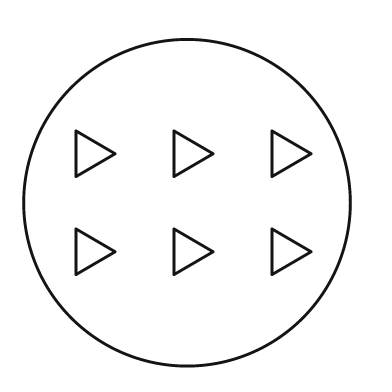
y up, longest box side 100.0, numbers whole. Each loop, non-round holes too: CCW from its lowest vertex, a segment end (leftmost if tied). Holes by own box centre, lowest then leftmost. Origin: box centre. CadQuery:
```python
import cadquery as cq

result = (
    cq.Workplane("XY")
    .moveTo(0.0, 0.0)
    .circle(50.0)
    .moveTo(-34.0, -22.0)
    .lineTo(-22.0, -15.0)
    .lineTo(-34.0, -8.0)
    .close()
    .moveTo(-4.0, -22.0)
    .lineTo(8.0, -15.0)
    .lineTo(-4.0, -8.0)
    .close()
    .moveTo(26.0, -22.0)
    .lineTo(38.0, -15.0)
    .lineTo(26.0, -8.0)
    .close()
    .moveTo(-34.0, 8.0)
    .lineTo(-22.0, 15.0)
    .lineTo(-34.0, 22.0)
    .close()
    .moveTo(-4.0, 8.0)
    .lineTo(8.0, 15.0)
    .lineTo(-4.0, 22.0)
    .close()
    .moveTo(26.0, 8.0)
    .lineTo(38.0, 15.0)
    .lineTo(26.0, 22.0)
    .close()
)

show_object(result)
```